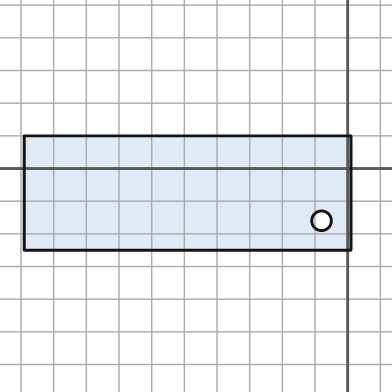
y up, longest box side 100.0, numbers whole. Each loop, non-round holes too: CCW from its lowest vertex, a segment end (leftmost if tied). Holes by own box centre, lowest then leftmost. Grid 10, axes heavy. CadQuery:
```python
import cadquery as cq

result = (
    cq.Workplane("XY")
    .moveTo(-99.0, -25.0)
    .lineTo(1.0, -25.0)
    .lineTo(1.0, 10.0)
    .lineTo(-99.0, 10.0)
    .close()
    .moveTo(-8.0, -16.0)
    .circle(3.0)
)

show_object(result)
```